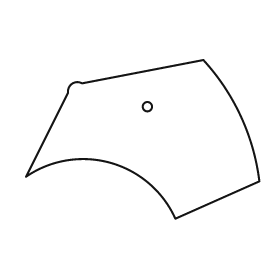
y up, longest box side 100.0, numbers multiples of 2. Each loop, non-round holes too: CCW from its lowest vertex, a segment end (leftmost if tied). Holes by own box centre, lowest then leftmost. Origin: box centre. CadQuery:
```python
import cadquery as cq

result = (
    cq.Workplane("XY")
    .moveTo(14.0, -34.0)
    .lineTo(50.0, -18.0)
    .threePointArc((42.0, 10.0), (26.0, 34.0))
    .lineTo(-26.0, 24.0)
    .threePointArc((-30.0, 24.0), (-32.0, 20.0))
    .lineTo(-50.0, -16.0)
    .threePointArc((-14.0, -10.0), (14.0, -34.0))
    .close()
    .moveTo(2.0, 14.0)
    .circle(2.0)
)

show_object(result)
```